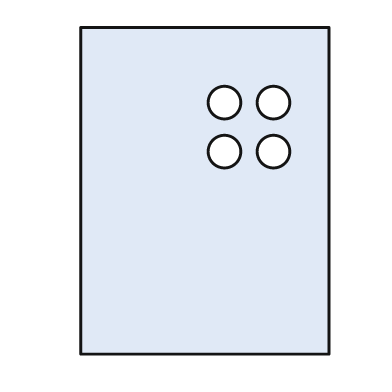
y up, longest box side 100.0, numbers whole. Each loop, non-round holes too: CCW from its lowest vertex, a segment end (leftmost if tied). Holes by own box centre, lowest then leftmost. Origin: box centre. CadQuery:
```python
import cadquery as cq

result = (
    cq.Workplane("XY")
    .moveTo(-38.0, -50.0)
    .lineTo(38.0, -50.0)
    .lineTo(38.0, 50.0)
    .lineTo(-38.0, 50.0)
    .close()
    .moveTo(6.0, 12.0)
    .circle(5.0)
    .moveTo(21.0, 12.0)
    .circle(5.0)
    .moveTo(6.0, 27.0)
    .circle(5.0)
    .moveTo(21.0, 27.0)
    .circle(5.0)
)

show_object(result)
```